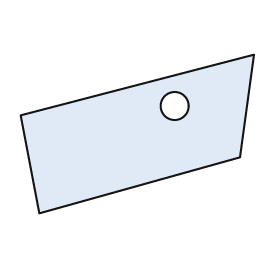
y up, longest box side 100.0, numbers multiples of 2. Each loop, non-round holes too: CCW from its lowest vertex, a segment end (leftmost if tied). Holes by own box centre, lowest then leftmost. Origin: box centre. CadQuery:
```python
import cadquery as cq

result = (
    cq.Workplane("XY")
    .moveTo(-42.0, -34.0)
    .lineTo(44.0, -10.0)
    .lineTo(50.0, 34.0)
    .lineTo(-50.0, 8.0)
    .close()
    .moveTo(16.0, 12.0)
    .circle(6.0)
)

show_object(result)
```